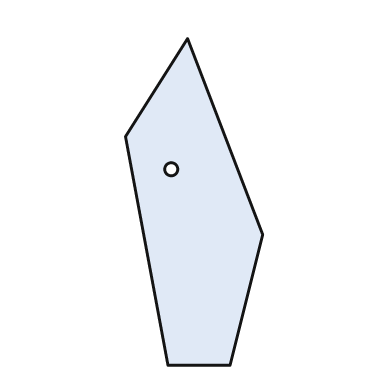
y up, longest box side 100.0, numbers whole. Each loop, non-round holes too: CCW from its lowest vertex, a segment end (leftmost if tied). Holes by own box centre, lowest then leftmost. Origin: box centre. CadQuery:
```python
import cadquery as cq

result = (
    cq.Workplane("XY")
    .moveTo(-8.0, -50.0)
    .lineTo(11.0, -50.0)
    .lineTo(21.0, -10.0)
    .lineTo(-2.0, 50.0)
    .lineTo(-21.0, 20.0)
    .close()
    .moveTo(-7.0, 10.0)
    .circle(2.0)
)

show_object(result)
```